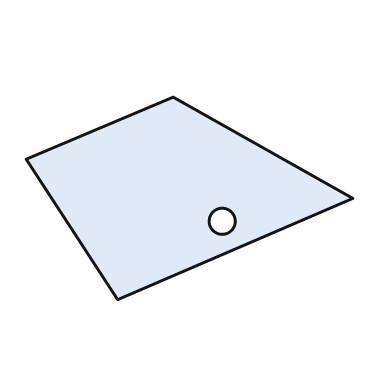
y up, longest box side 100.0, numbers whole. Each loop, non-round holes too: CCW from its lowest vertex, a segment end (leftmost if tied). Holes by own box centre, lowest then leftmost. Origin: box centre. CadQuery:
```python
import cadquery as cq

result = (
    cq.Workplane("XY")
    .moveTo(-22.0, -31.0)
    .lineTo(50.0, 0.0)
    .lineTo(-5.0, 31.0)
    .lineTo(-50.0, 12.0)
    .close()
    .moveTo(10.0, -7.0)
    .circle(4.0)
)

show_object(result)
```